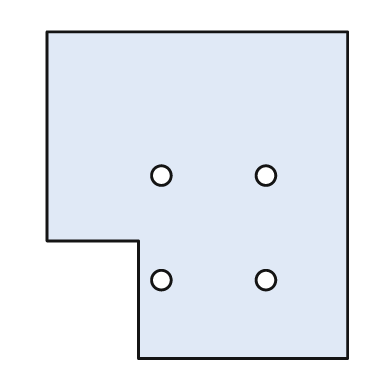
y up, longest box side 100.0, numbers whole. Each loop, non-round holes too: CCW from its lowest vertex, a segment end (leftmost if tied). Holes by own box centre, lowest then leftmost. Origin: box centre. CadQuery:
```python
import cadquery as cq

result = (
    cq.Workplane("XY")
    .moveTo(-18.0, -50.0)
    .lineTo(46.0, -50.0)
    .lineTo(46.0, 50.0)
    .lineTo(-46.0, 50.0)
    .lineTo(-46.0, -14.0)
    .lineTo(-18.0, -14.0)
    .close()
    .moveTo(-11.0, -26.0)
    .circle(3.0)
    .moveTo(21.0, -26.0)
    .circle(3.0)
    .moveTo(-11.0, 6.0)
    .circle(3.0)
    .moveTo(21.0, 6.0)
    .circle(3.0)
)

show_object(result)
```